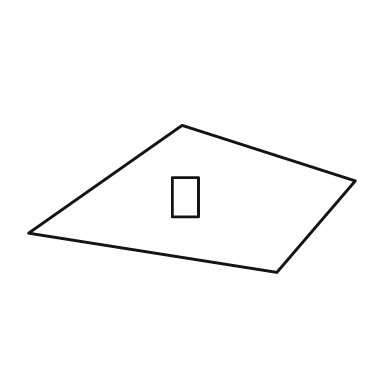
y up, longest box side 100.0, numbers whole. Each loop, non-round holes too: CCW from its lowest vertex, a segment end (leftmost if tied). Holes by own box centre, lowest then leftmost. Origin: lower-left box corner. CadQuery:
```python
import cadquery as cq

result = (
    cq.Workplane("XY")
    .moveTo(76.0, 0.0)
    .lineTo(100.0, 28.0)
    .lineTo(47.0, 45.0)
    .lineTo(0.0, 12.0)
    .close()
    .moveTo(44.0, 17.0)
    .lineTo(52.0, 17.0)
    .lineTo(52.0, 29.0)
    .lineTo(44.0, 29.0)
    .close()
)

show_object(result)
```